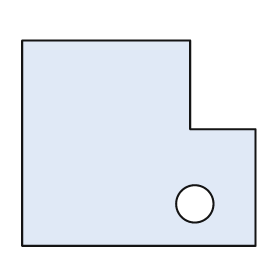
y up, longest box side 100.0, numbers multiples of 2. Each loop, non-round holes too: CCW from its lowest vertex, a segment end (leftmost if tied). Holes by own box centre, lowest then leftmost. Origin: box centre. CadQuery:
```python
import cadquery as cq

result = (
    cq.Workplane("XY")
    .moveTo(-50.0, -44.0)
    .lineTo(50.0, -44.0)
    .lineTo(50.0, 6.0)
    .lineTo(22.0, 6.0)
    .lineTo(22.0, 44.0)
    .lineTo(-50.0, 44.0)
    .close()
    .moveTo(24.0, -26.0)
    .circle(8.0)
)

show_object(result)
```